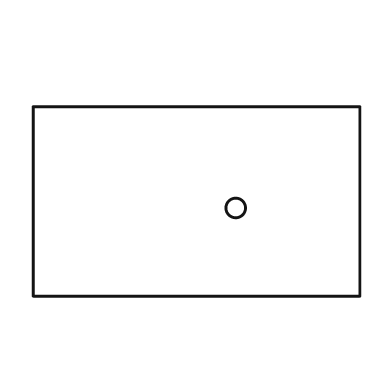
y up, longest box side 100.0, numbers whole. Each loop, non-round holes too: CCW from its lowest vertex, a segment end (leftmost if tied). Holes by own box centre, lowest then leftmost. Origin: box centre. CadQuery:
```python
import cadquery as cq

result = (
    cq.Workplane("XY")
    .moveTo(-50.0, -29.0)
    .lineTo(50.0, -29.0)
    .lineTo(50.0, 29.0)
    .lineTo(-50.0, 29.0)
    .close()
    .moveTo(12.0, -2.0)
    .circle(3.0)
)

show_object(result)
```